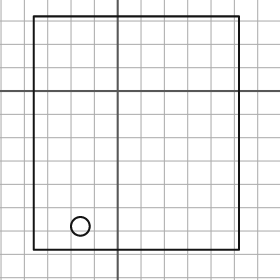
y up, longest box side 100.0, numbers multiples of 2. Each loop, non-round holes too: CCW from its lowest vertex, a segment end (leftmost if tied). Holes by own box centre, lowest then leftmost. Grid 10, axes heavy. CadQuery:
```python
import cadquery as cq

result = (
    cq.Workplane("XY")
    .moveTo(-36.0, -68.0)
    .lineTo(52.0, -68.0)
    .lineTo(52.0, 32.0)
    .lineTo(-36.0, 32.0)
    .close()
    .moveTo(-16.0, -58.0)
    .circle(4.0)
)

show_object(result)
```